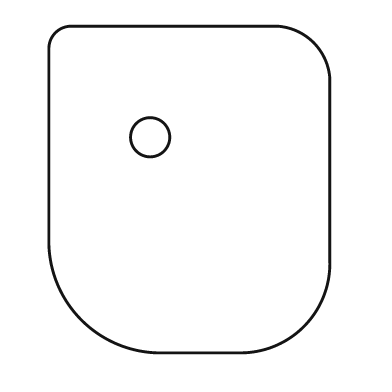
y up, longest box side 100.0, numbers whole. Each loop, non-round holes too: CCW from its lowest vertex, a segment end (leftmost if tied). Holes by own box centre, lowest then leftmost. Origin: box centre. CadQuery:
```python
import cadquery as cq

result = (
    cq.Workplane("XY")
    .moveTo(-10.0, -50.0)
    .lineTo(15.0, -50.0)
    .threePointArc((35.0, -42.0), (43.0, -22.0))
    .lineTo(43.0, 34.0)
    .threePointArc((38.0, 45.0), (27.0, 50.0))
    .lineTo(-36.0, 50.0)
    .threePointArc((-41.0, 48.0), (-43.0, 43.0))
    .lineTo(-43.0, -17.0)
    .threePointArc((-33.0, -40.0), (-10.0, -50.0))
    .close()
    .moveTo(-12.0, 16.0)
    .circle(6.0)
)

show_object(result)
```